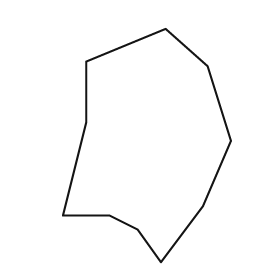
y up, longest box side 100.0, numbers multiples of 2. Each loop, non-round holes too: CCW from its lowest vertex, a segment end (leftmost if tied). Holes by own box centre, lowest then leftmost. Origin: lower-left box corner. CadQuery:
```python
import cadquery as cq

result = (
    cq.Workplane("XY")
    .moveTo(42.0, 0.0)
    .lineTo(60.0, 24.0)
    .lineTo(72.0, 52.0)
    .lineTo(62.0, 84.0)
    .lineTo(44.0, 100.0)
    .lineTo(10.0, 86.0)
    .lineTo(10.0, 60.0)
    .lineTo(0.0, 20.0)
    .lineTo(20.0, 20.0)
    .lineTo(32.0, 14.0)
    .close()
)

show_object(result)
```